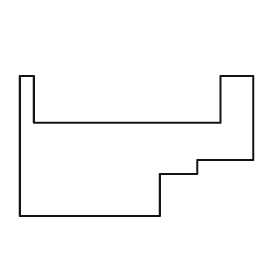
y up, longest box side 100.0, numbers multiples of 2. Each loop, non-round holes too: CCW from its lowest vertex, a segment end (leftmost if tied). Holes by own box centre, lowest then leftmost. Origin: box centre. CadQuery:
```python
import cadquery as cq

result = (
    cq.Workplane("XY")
    .moveTo(-50.0, -30.0)
    .lineTo(10.0, -30.0)
    .lineTo(10.0, -12.0)
    .lineTo(26.0, -12.0)
    .lineTo(26.0, -6.0)
    .lineTo(50.0, -6.0)
    .lineTo(50.0, 30.0)
    .lineTo(36.0, 30.0)
    .lineTo(36.0, 10.0)
    .lineTo(-44.0, 10.0)
    .lineTo(-44.0, 30.0)
    .lineTo(-50.0, 30.0)
    .close()
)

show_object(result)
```